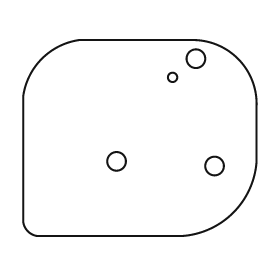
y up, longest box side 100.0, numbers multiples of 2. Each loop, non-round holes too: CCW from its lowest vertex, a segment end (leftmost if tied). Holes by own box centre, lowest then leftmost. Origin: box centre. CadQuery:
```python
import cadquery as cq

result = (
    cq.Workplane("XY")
    .moveTo(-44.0, -42.0)
    .lineTo(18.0, -42.0)
    .threePointArc((40.0, -32.0), (50.0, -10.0))
    .lineTo(50.0, 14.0)
    .threePointArc((42.0, 34.0), (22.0, 42.0))
    .lineTo(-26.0, 42.0)
    .threePointArc((-42.0, 34.0), (-50.0, 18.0))
    .lineTo(-50.0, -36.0)
    .threePointArc((-48.0, -40.0), (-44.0, -42.0))
    .close()
    .moveTo(32.0, -12.0)
    .circle(4.0)
    .moveTo(-10.0, -10.0)
    .circle(4.0)
    .moveTo(14.0, 26.0)
    .circle(2.0)
    .moveTo(24.0, 34.0)
    .circle(4.0)
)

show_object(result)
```